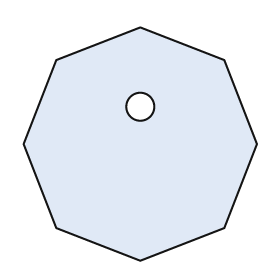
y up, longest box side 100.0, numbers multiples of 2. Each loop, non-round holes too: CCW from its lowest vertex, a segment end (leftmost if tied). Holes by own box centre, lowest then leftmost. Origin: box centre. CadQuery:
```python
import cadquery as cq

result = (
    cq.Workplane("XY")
    .moveTo(0.0, -50.0)
    .lineTo(36.0, -36.0)
    .lineTo(50.0, 0.0)
    .lineTo(36.0, 36.0)
    .lineTo(0.0, 50.0)
    .lineTo(-36.0, 36.0)
    .lineTo(-50.0, 0.0)
    .lineTo(-36.0, -36.0)
    .close()
    .moveTo(0.0, 16.0)
    .circle(6.0)
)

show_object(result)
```